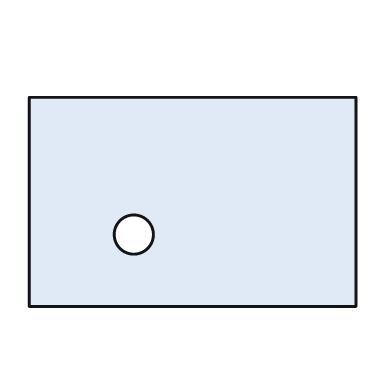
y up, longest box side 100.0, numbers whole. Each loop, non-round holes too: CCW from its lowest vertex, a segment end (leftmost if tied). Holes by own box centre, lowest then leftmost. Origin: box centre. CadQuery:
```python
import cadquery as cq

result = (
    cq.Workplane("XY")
    .moveTo(-50.0, -32.0)
    .lineTo(50.0, -32.0)
    .lineTo(50.0, 32.0)
    .lineTo(-50.0, 32.0)
    .close()
    .moveTo(-18.0, -10.0)
    .circle(6.0)
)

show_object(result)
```